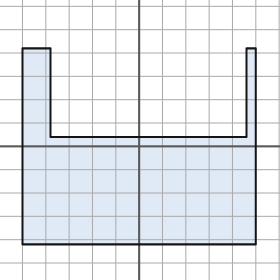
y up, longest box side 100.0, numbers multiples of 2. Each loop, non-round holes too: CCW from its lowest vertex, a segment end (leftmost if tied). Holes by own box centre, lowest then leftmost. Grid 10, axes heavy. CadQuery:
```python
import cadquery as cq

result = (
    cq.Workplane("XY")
    .moveTo(-50.0, -42.0)
    .lineTo(50.0, -42.0)
    .lineTo(50.0, 42.0)
    .lineTo(46.0, 42.0)
    .lineTo(46.0, 4.0)
    .lineTo(-38.0, 4.0)
    .lineTo(-38.0, 42.0)
    .lineTo(-50.0, 42.0)
    .close()
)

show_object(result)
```